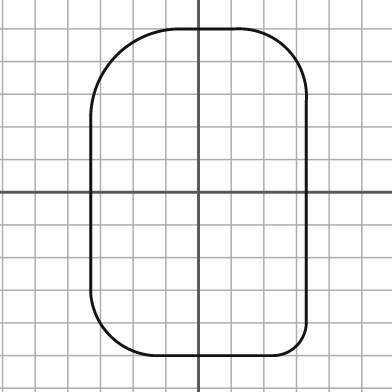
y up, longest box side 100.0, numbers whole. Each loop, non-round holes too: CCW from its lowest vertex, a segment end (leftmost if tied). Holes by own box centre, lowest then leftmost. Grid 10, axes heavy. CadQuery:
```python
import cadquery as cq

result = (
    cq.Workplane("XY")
    .moveTo(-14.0, -50.0)
    .lineTo(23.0, -50.0)
    .threePointArc((30.0, -47.0), (33.0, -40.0))
    .lineTo(33.0, 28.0)
    .threePointArc((27.0, 44.0), (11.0, 50.0))
    .lineTo(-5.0, 50.0)
    .threePointArc((-25.0, 42.0), (-33.0, 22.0))
    .lineTo(-33.0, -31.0)
    .threePointArc((-27.0, -44.0), (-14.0, -50.0))
    .close()
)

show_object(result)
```